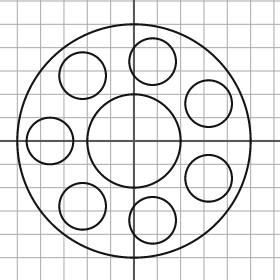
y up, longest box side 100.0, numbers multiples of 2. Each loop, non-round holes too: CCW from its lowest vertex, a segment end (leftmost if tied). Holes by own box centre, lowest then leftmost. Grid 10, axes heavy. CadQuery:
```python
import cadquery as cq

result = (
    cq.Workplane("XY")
    .moveTo(0.0, 0.0)
    .circle(50.0)
    .moveTo(8.0, -34.0)
    .circle(10.0)
    .moveTo(-22.0, -28.0)
    .circle(10.0)
    .moveTo(32.0, -16.0)
    .circle(10.0)
    .moveTo(-36.0, 0.0)
    .circle(10.0)
    .moveTo(0.0, 0.0)
    .circle(20.0)
    .moveTo(32.0, 16.0)
    .circle(10.0)
    .moveTo(-22.0, 28.0)
    .circle(10.0)
    .moveTo(8.0, 34.0)
    .circle(10.0)
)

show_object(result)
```